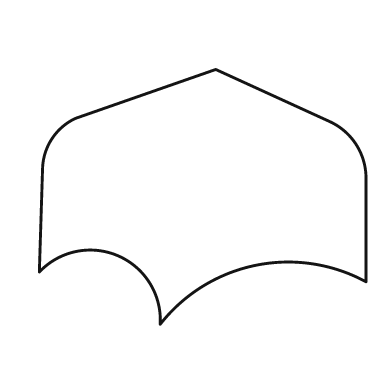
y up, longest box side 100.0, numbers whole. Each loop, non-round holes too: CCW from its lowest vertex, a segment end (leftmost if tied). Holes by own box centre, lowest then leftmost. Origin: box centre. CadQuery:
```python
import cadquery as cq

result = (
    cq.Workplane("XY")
    .moveTo(-13.0, -39.0)
    .threePointArc((16.0, -21.0), (50.0, -26.0))
    .lineTo(50.0, 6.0)
    .threePointArc((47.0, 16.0), (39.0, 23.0))
    .lineTo(4.0, 39.0)
    .lineTo(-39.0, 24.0)
    .threePointArc((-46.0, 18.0), (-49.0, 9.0))
    .lineTo(-50.0, -23.0)
    .threePointArc((-26.0, -18.0), (-13.0, -39.0))
    .close()
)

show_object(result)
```